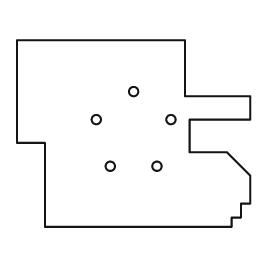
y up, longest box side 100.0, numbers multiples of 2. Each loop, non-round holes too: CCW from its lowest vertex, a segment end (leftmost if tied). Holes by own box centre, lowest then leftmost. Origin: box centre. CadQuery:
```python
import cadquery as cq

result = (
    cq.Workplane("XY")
    .moveTo(-38.0, -40.0)
    .lineTo(42.0, -40.0)
    .lineTo(42.0, -36.0)
    .lineTo(46.0, -36.0)
    .lineTo(46.0, -30.0)
    .lineTo(50.0, -30.0)
    .lineTo(50.0, -18.0)
    .lineTo(40.0, -8.0)
    .lineTo(24.0, -8.0)
    .lineTo(24.0, 6.0)
    .lineTo(50.0, 6.0)
    .lineTo(50.0, 16.0)
    .lineTo(22.0, 16.0)
    .lineTo(22.0, 40.0)
    .lineTo(-50.0, 40.0)
    .lineTo(-50.0, -4.0)
    .lineTo(-38.0, -4.0)
    .close()
    .moveTo(-10.0, -14.0)
    .circle(2.0)
    .moveTo(10.0, -14.0)
    .circle(2.0)
    .moveTo(-16.0, 6.0)
    .circle(2.0)
    .moveTo(16.0, 6.0)
    .circle(2.0)
    .moveTo(0.0, 18.0)
    .circle(2.0)
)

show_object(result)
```